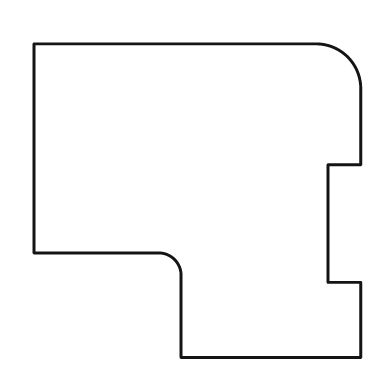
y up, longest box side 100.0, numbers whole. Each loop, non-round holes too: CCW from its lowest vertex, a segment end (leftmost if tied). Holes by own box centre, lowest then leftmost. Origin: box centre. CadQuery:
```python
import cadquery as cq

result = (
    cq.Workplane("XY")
    .moveTo(-5.0, -48.0)
    .lineTo(50.0, -48.0)
    .lineTo(50.0, -25.0)
    .lineTo(40.0, -25.0)
    .lineTo(40.0, 11.0)
    .lineTo(50.0, 11.0)
    .lineTo(50.0, 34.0)
    .threePointArc((46.0, 44.0), (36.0, 48.0))
    .lineTo(-50.0, 48.0)
    .lineTo(-50.0, -16.0)
    .lineTo(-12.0, -16.0)
    .threePointArc((-7.0, -18.0), (-5.0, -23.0))
    .close()
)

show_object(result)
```